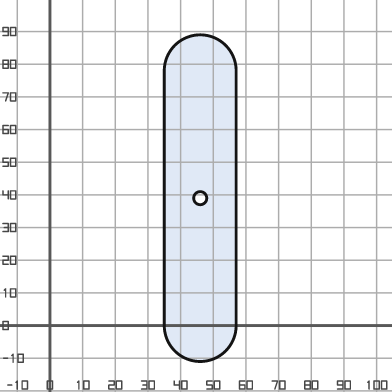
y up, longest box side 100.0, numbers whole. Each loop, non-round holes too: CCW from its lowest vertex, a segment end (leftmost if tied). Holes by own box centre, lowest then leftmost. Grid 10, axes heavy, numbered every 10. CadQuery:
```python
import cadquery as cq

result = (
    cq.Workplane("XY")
    .moveTo(35.0, 0.0)
    .threePointArc((46.0, -11.0), (57.0, 0.0))
    .lineTo(57.0, 78.0)
    .threePointArc((46.0, 89.0), (35.0, 78.0))
    .close()
    .moveTo(46.0, 39.0)
    .circle(2.0)
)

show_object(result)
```